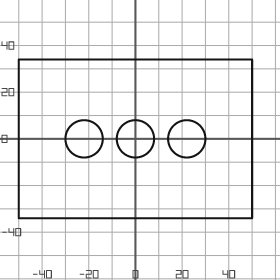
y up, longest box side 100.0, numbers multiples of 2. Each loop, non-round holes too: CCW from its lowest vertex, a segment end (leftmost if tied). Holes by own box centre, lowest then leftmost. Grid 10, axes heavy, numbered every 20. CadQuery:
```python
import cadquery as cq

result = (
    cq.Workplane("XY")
    .moveTo(-50.0, -34.0)
    .lineTo(50.0, -34.0)
    .lineTo(50.0, 34.0)
    .lineTo(-50.0, 34.0)
    .close()
    .moveTo(-22.0, 0.0)
    .circle(8.0)
    .moveTo(0.0, 0.0)
    .circle(8.0)
    .moveTo(22.0, 0.0)
    .circle(8.0)
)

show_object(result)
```